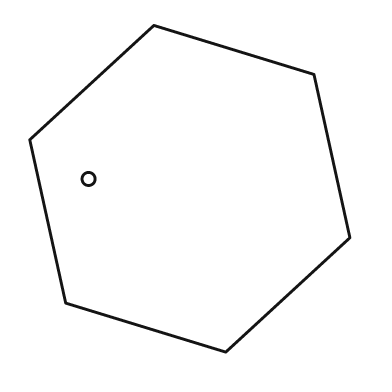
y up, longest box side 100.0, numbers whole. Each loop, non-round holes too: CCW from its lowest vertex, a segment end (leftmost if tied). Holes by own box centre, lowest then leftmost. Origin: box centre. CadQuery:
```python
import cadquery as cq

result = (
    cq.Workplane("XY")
    .moveTo(11.0, -50.0)
    .lineTo(49.0, -15.0)
    .lineTo(38.0, 35.0)
    .lineTo(-11.0, 50.0)
    .lineTo(-49.0, 15.0)
    .lineTo(-38.0, -35.0)
    .close()
    .moveTo(-31.0, 3.0)
    .circle(2.0)
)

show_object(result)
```